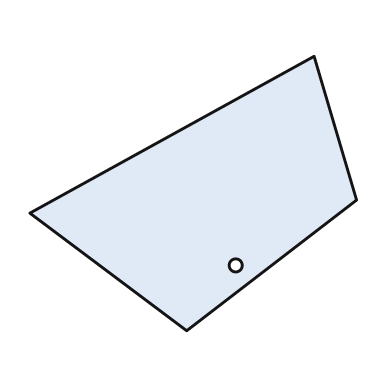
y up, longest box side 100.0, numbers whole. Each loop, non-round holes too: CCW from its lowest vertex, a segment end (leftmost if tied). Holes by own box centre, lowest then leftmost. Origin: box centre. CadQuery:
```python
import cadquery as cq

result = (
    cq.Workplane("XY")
    .moveTo(-2.0, -42.0)
    .lineTo(50.0, -2.0)
    .lineTo(37.0, 42.0)
    .lineTo(-50.0, -6.0)
    .close()
    .moveTo(13.0, -22.0)
    .circle(2.0)
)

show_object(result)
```